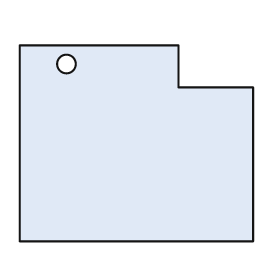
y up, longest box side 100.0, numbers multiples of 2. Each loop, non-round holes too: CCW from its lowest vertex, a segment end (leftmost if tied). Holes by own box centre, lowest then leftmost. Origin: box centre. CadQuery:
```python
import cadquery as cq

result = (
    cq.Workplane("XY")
    .moveTo(-50.0, -42.0)
    .lineTo(50.0, -42.0)
    .lineTo(50.0, 24.0)
    .lineTo(18.0, 24.0)
    .lineTo(18.0, 42.0)
    .lineTo(-50.0, 42.0)
    .close()
    .moveTo(-30.0, 34.0)
    .circle(4.0)
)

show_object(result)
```